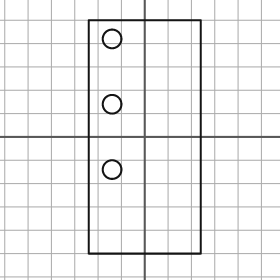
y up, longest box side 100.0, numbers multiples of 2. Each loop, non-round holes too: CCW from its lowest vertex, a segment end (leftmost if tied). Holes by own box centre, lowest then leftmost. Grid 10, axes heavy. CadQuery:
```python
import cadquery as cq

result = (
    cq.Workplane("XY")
    .moveTo(-24.0, -50.0)
    .lineTo(24.0, -50.0)
    .lineTo(24.0, 50.0)
    .lineTo(-24.0, 50.0)
    .close()
    .moveTo(-14.0, -14.0)
    .circle(4.0)
    .moveTo(-14.0, 14.0)
    .circle(4.0)
    .moveTo(-14.0, 42.0)
    .circle(4.0)
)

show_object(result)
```